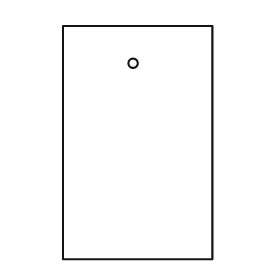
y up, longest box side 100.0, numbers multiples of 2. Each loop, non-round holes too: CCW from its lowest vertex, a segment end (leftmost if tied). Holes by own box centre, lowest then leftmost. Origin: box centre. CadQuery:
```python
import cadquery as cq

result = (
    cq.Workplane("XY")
    .moveTo(-32.0, -50.0)
    .lineTo(32.0, -50.0)
    .lineTo(32.0, 50.0)
    .lineTo(-32.0, 50.0)
    .close()
    .moveTo(-2.0, 34.0)
    .circle(2.0)
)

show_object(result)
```